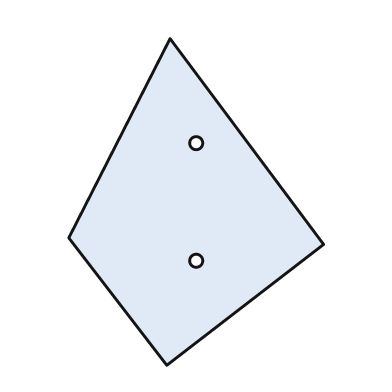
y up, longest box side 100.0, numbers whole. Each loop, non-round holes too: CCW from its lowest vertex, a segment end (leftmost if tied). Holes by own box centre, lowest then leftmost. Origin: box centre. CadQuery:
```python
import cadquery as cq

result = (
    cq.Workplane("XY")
    .moveTo(-9.0, -50.0)
    .lineTo(39.0, -13.0)
    .lineTo(-8.0, 50.0)
    .lineTo(-39.0, -11.0)
    .close()
    .moveTo(0.0, -18.0)
    .circle(2.0)
    .moveTo(0.0, 18.0)
    .circle(2.0)
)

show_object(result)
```